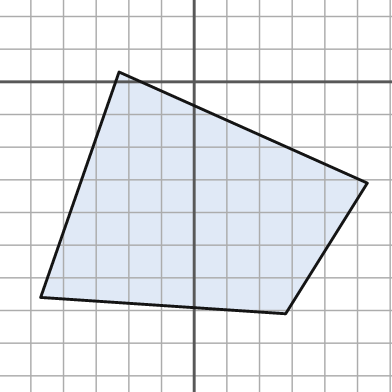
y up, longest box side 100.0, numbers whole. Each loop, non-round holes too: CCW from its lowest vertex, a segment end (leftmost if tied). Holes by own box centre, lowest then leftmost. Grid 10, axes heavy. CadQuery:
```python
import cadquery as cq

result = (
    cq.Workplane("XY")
    .moveTo(28.0, -71.0)
    .lineTo(53.0, -31.0)
    .lineTo(-23.0, 3.0)
    .lineTo(-47.0, -66.0)
    .close()
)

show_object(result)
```